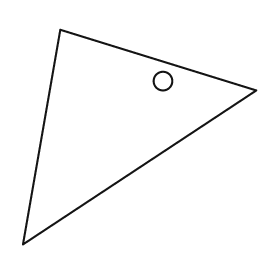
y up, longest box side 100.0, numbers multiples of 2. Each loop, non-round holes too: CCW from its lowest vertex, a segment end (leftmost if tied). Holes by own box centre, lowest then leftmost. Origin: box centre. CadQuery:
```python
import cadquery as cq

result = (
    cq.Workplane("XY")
    .moveTo(-50.0, -46.0)
    .lineTo(50.0, 20.0)
    .lineTo(-34.0, 46.0)
    .close()
    .moveTo(10.0, 24.0)
    .circle(4.0)
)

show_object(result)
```